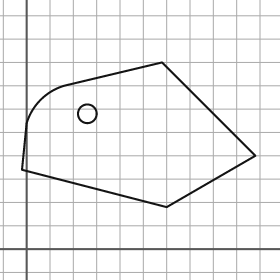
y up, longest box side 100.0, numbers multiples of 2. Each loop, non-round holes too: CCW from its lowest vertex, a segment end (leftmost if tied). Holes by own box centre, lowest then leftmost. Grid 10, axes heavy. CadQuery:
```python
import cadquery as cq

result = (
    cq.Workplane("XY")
    .moveTo(60.0, 18.0)
    .lineTo(98.0, 40.0)
    .lineTo(58.0, 80.0)
    .lineTo(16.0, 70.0)
    .threePointArc((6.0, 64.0), (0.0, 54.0))
    .lineTo(-2.0, 34.0)
    .close()
    .moveTo(26.0, 58.0)
    .circle(4.0)
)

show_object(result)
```